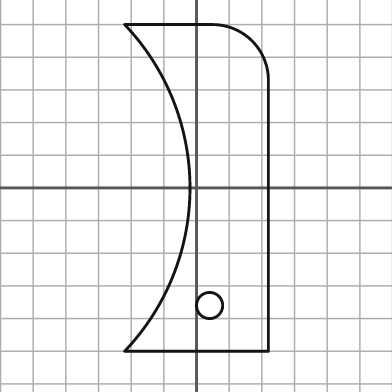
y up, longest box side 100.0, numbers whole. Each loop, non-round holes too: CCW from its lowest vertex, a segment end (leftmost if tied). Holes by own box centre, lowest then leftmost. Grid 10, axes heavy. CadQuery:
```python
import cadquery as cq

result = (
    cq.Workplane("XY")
    .moveTo(-22.0, -50.0)
    .lineTo(22.0, -50.0)
    .lineTo(22.0, 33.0)
    .threePointArc((17.0, 45.0), (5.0, 50.0))
    .lineTo(-22.0, 50.0)
    .threePointArc((-2.0, 0.0), (-22.0, -50.0))
    .close()
    .moveTo(4.0, -36.0)
    .circle(4.0)
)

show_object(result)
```